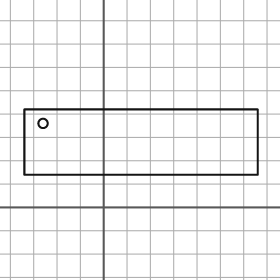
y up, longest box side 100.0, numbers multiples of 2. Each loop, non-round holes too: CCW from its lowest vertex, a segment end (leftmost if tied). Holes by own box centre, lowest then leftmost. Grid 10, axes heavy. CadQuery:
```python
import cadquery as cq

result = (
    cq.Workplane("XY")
    .moveTo(-34.0, 14.0)
    .lineTo(66.0, 14.0)
    .lineTo(66.0, 42.0)
    .lineTo(-34.0, 42.0)
    .close()
    .moveTo(-26.0, 36.0)
    .circle(2.0)
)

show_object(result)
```